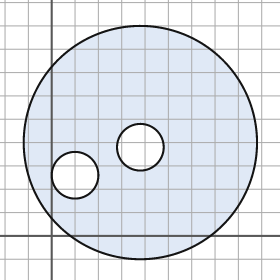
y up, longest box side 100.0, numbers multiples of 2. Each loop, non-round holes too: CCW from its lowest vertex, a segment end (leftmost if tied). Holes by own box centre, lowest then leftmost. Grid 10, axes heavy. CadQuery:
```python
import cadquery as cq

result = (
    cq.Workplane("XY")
    .moveTo(38.0, 40.0)
    .circle(50.0)
    .moveTo(10.0, 26.0)
    .circle(10.0)
    .moveTo(38.0, 38.0)
    .circle(10.0)
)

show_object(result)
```